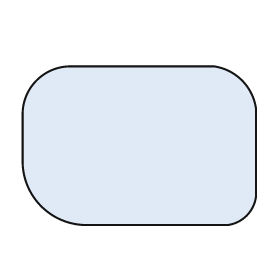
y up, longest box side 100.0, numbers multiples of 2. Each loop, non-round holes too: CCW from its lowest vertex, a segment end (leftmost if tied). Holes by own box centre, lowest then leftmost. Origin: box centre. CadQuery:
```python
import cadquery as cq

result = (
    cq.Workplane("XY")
    .moveTo(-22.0, -34.0)
    .lineTo(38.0, -34.0)
    .threePointArc((46.0, -30.0), (50.0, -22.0))
    .lineTo(50.0, 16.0)
    .threePointArc((44.0, 28.0), (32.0, 34.0))
    .lineTo(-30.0, 34.0)
    .threePointArc((-44.0, 28.0), (-50.0, 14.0))
    .lineTo(-50.0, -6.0)
    .threePointArc((-42.0, -26.0), (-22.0, -34.0))
    .close()
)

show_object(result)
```